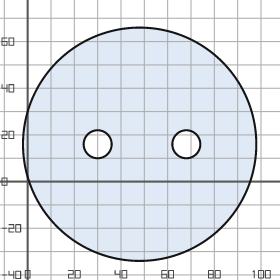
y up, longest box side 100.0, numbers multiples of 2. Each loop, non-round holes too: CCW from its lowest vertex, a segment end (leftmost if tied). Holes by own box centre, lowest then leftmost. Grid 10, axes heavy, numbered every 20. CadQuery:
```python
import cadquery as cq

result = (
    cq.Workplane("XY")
    .moveTo(48.0, 16.0)
    .circle(50.0)
    .moveTo(30.0, 16.0)
    .circle(6.0)
    .moveTo(68.0, 16.0)
    .circle(6.0)
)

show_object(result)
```